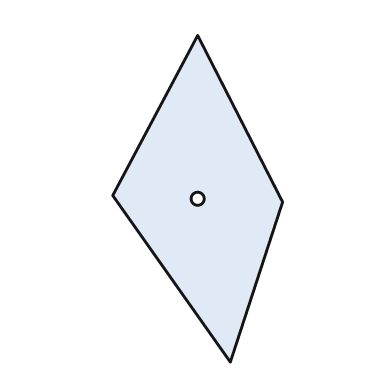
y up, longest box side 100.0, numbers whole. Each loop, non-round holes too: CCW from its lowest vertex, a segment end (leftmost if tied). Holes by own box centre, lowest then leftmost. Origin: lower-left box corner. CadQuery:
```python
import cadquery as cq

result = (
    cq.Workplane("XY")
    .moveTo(36.0, 0.0)
    .lineTo(52.0, 49.0)
    .lineTo(26.0, 100.0)
    .lineTo(0.0, 51.0)
    .close()
    .moveTo(26.0, 50.0)
    .circle(2.0)
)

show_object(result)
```